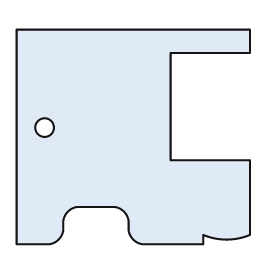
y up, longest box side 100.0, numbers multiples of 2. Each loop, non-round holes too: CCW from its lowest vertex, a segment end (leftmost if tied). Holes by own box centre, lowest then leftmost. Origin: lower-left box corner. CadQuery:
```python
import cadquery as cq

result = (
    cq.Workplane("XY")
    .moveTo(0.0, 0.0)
    .lineTo(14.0, 0.0)
    .threePointArc((18.0, 2.0), (20.0, 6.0))
    .lineTo(20.0, 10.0)
    .threePointArc((22.0, 14.0), (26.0, 16.0))
    .lineTo(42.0, 16.0)
    .threePointArc((46.0, 14.0), (48.0, 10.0))
    .lineTo(48.0, 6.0)
    .threePointArc((50.0, 2.0), (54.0, 0.0))
    .lineTo(80.0, 0.0)
    .lineTo(80.0, 4.0)
    .threePointArc((90.0, 2.0), (100.0, 4.0))
    .lineTo(100.0, 36.0)
    .lineTo(66.0, 36.0)
    .lineTo(66.0, 82.0)
    .lineTo(100.0, 82.0)
    .lineTo(100.0, 92.0)
    .lineTo(0.0, 92.0)
    .close()
    .moveTo(12.0, 50.0)
    .circle(4.0)
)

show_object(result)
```